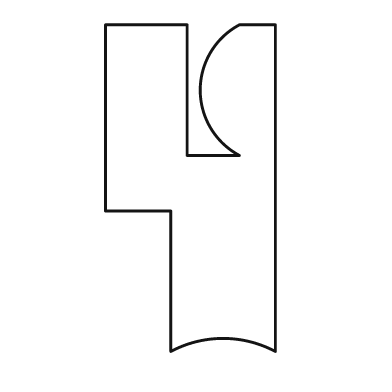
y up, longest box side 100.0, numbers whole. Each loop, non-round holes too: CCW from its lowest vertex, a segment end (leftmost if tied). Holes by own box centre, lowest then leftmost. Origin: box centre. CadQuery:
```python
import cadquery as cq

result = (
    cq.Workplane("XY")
    .moveTo(-6.0, -50.0)
    .threePointArc((10.0, -46.0), (26.0, -50.0))
    .lineTo(26.0, 50.0)
    .lineTo(15.0, 50.0)
    .threePointArc((3.0, 30.0), (15.0, 10.0))
    .lineTo(-1.0, 10.0)
    .lineTo(-1.0, 50.0)
    .lineTo(-26.0, 50.0)
    .lineTo(-26.0, -7.0)
    .lineTo(-6.0, -7.0)
    .close()
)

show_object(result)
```